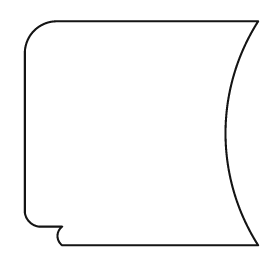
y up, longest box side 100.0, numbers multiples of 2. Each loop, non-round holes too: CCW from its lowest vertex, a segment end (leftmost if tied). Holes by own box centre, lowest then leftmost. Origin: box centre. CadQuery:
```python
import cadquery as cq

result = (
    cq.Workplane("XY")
    .moveTo(-34.0, -48.0)
    .lineTo(50.0, -48.0)
    .threePointArc((36.0, 0.0), (50.0, 48.0))
    .lineTo(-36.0, 48.0)
    .threePointArc((-46.0, 44.0), (-50.0, 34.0))
    .lineTo(-50.0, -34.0)
    .threePointArc((-48.0, -38.0), (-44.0, -40.0))
    .lineTo(-34.0, -40.0)
    .threePointArc((-36.0, -44.0), (-34.0, -48.0))
    .close()
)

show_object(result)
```